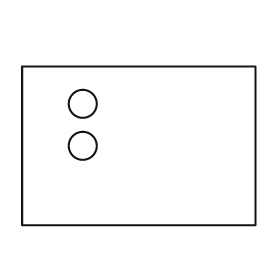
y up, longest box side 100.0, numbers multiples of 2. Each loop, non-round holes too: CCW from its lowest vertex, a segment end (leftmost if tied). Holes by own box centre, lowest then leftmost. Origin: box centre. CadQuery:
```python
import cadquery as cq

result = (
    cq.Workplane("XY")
    .moveTo(-50.0, -34.0)
    .lineTo(50.0, -34.0)
    .lineTo(50.0, 34.0)
    .lineTo(-50.0, 34.0)
    .close()
    .moveTo(-24.0, 0.0)
    .circle(6.0)
    .moveTo(-24.0, 18.0)
    .circle(6.0)
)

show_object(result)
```